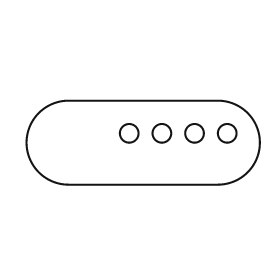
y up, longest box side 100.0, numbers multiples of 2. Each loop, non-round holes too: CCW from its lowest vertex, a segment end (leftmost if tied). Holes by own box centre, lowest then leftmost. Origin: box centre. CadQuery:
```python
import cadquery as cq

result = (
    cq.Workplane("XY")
    .moveTo(-32.0, -18.0)
    .lineTo(32.0, -18.0)
    .threePointArc((50.0, 0.0), (32.0, 18.0))
    .lineTo(-32.0, 18.0)
    .threePointArc((-50.0, 0.0), (-32.0, -18.0))
    .close()
    .moveTo(-6.0, 4.0)
    .circle(4.0)
    .moveTo(8.0, 4.0)
    .circle(4.0)
    .moveTo(22.0, 4.0)
    .circle(4.0)
    .moveTo(36.0, 4.0)
    .circle(4.0)
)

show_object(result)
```